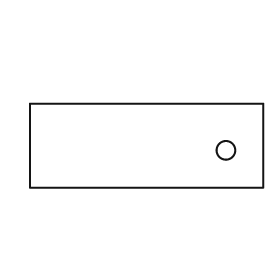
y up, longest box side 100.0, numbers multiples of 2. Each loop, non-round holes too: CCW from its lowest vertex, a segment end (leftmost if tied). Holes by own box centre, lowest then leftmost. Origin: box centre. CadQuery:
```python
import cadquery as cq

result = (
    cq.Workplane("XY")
    .moveTo(-50.0, -18.0)
    .lineTo(50.0, -18.0)
    .lineTo(50.0, 18.0)
    .lineTo(-50.0, 18.0)
    .close()
    .moveTo(34.0, -2.0)
    .circle(4.0)
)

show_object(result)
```